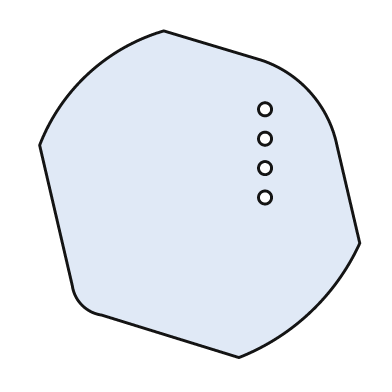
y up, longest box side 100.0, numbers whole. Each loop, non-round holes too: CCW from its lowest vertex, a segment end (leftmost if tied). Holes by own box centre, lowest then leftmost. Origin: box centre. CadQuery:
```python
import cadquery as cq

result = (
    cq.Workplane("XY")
    .moveTo(12.0, -50.0)
    .threePointArc((34.0, -36.0), (49.0, -15.0))
    .lineTo(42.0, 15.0)
    .threePointArc((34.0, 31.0), (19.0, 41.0))
    .lineTo(-11.0, 50.0)
    .threePointArc((-34.0, 37.0), (-49.0, 15.0))
    .lineTo(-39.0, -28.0)
    .threePointArc((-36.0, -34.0), (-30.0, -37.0))
    .close()
    .moveTo(20.0, -1.0)
    .circle(2.0)
    .moveTo(20.0, 8.0)
    .circle(2.0)
    .moveTo(20.0, 17.0)
    .circle(2.0)
    .moveTo(20.0, 26.0)
    .circle(2.0)
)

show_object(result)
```